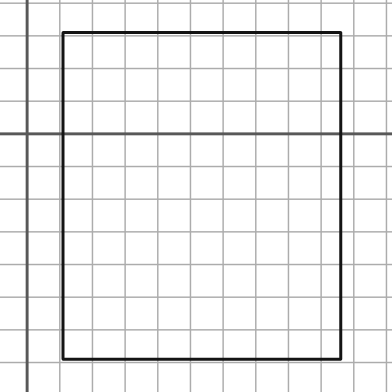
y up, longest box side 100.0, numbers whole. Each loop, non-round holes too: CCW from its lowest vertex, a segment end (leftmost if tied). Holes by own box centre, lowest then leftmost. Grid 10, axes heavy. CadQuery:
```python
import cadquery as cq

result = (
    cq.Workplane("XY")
    .moveTo(11.0, -69.0)
    .lineTo(96.0, -69.0)
    .lineTo(96.0, 31.0)
    .lineTo(11.0, 31.0)
    .close()
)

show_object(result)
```